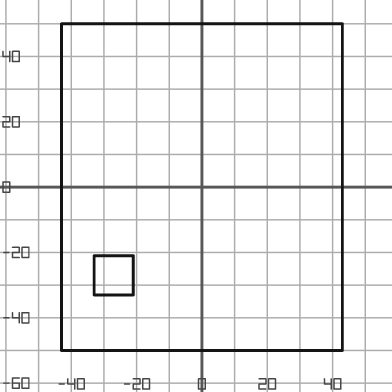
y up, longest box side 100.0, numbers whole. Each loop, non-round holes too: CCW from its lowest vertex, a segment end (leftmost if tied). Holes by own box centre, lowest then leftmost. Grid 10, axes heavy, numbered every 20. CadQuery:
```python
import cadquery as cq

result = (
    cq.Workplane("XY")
    .moveTo(-43.0, -50.0)
    .lineTo(43.0, -50.0)
    .lineTo(43.0, 50.0)
    .lineTo(-43.0, 50.0)
    .close()
    .moveTo(-33.0, -33.0)
    .lineTo(-21.0, -33.0)
    .lineTo(-21.0, -21.0)
    .lineTo(-33.0, -21.0)
    .close()
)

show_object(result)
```